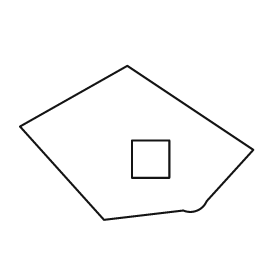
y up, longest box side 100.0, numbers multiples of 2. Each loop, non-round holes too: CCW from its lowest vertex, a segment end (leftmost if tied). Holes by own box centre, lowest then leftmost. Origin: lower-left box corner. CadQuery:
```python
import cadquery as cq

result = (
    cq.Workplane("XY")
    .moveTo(36.0, 0.0)
    .lineTo(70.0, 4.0)
    .threePointArc((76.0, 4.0), (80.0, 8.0))
    .lineTo(100.0, 30.0)
    .lineTo(46.0, 66.0)
    .lineTo(0.0, 40.0)
    .close()
    .moveTo(48.0, 18.0)
    .lineTo(64.0, 18.0)
    .lineTo(64.0, 34.0)
    .lineTo(48.0, 34.0)
    .close()
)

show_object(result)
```